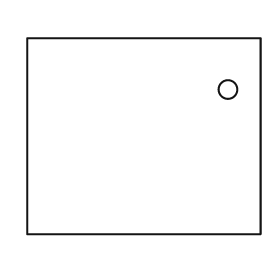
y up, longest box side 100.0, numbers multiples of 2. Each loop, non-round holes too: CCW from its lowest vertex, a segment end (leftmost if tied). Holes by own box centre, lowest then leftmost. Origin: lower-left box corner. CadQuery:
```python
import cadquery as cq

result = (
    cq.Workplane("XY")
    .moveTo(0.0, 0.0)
    .lineTo(100.0, 0.0)
    .lineTo(100.0, 84.0)
    .lineTo(0.0, 84.0)
    .close()
    .moveTo(86.0, 62.0)
    .circle(4.0)
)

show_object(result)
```